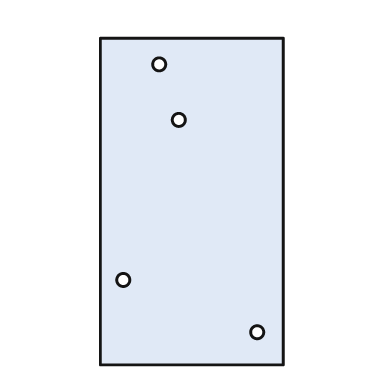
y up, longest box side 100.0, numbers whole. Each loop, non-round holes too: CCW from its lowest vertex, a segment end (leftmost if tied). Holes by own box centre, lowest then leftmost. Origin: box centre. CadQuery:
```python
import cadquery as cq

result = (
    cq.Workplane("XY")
    .moveTo(-28.0, -50.0)
    .lineTo(28.0, -50.0)
    .lineTo(28.0, 50.0)
    .lineTo(-28.0, 50.0)
    .close()
    .moveTo(20.0, -40.0)
    .circle(2.0)
    .moveTo(-21.0, -24.0)
    .circle(2.0)
    .moveTo(-4.0, 25.0)
    .circle(2.0)
    .moveTo(-10.0, 42.0)
    .circle(2.0)
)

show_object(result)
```